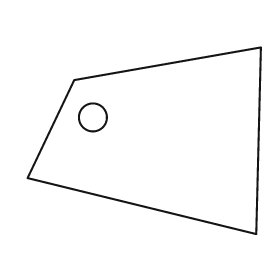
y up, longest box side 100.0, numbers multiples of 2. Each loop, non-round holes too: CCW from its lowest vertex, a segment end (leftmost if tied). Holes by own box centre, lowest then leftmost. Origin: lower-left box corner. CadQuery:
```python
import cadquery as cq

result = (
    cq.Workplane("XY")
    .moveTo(98.0, 0.0)
    .lineTo(100.0, 80.0)
    .lineTo(20.0, 66.0)
    .lineTo(0.0, 24.0)
    .close()
    .moveTo(28.0, 50.0)
    .circle(6.0)
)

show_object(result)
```